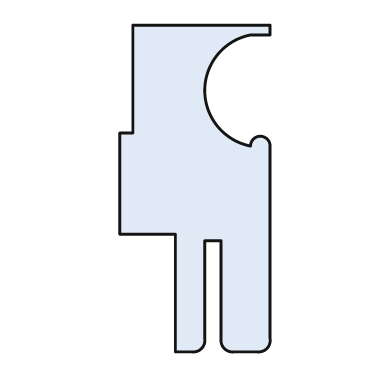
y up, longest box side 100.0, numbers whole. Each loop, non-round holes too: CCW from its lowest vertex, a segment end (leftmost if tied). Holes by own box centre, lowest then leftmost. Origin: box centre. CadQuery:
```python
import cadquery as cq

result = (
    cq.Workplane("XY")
    .moveTo(-6.0, -50.0)
    .lineTo(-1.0, -50.0)
    .threePointArc((2.0, -49.0), (3.0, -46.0))
    .lineTo(3.0, -16.0)
    .lineTo(8.0, -16.0)
    .lineTo(8.0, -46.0)
    .threePointArc((9.0, -49.0), (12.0, -50.0))
    .lineTo(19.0, -50.0)
    .threePointArc((22.0, -49.0), (23.0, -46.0))
    .lineTo(23.0, 13.0)
    .threePointArc((20.0, 16.0), (17.0, 13.0))
    .threePointArc((3.0, 30.0), (17.0, 47.0))
    .lineTo(23.0, 47.0)
    .lineTo(23.0, 50.0)
    .lineTo(-19.0, 50.0)
    .lineTo(-19.0, 17.0)
    .lineTo(-23.0, 17.0)
    .lineTo(-23.0, -14.0)
    .lineTo(-6.0, -14.0)
    .close()
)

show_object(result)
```